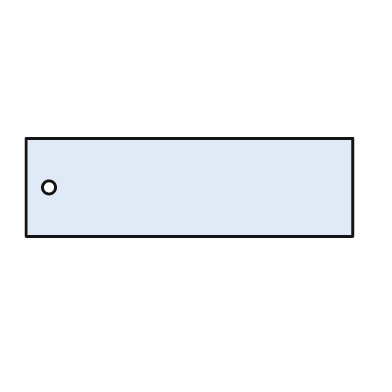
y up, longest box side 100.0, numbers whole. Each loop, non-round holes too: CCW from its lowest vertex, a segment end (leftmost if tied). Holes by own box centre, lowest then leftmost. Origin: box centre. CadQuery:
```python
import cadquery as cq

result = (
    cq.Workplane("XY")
    .moveTo(-50.0, -15.0)
    .lineTo(50.0, -15.0)
    .lineTo(50.0, 15.0)
    .lineTo(-50.0, 15.0)
    .close()
    .moveTo(-43.0, 0.0)
    .circle(2.0)
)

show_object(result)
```